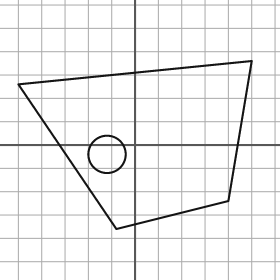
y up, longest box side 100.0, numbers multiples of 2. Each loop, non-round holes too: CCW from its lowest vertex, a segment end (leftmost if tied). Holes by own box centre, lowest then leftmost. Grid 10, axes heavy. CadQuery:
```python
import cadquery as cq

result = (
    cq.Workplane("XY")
    .moveTo(-8.0, -36.0)
    .lineTo(40.0, -24.0)
    .lineTo(50.0, 36.0)
    .lineTo(-50.0, 26.0)
    .close()
    .moveTo(-12.0, -4.0)
    .circle(8.0)
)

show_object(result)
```